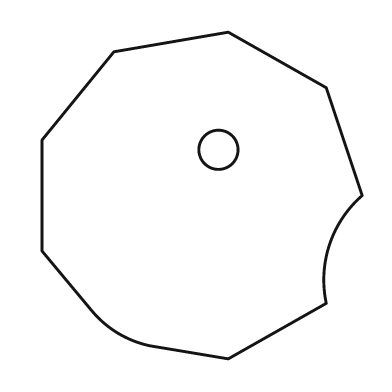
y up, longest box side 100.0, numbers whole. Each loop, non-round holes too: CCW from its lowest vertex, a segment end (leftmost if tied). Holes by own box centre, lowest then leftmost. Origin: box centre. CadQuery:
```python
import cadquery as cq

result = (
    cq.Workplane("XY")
    .moveTo(8.0, -50.0)
    .lineTo(38.0, -33.0)
    .threePointArc((39.0, -15.0), (49.0, 0.0))
    .lineTo(38.0, 33.0)
    .lineTo(8.0, 50.0)
    .lineTo(-27.0, 44.0)
    .lineTo(-49.0, 17.0)
    .lineTo(-49.0, -17.0)
    .lineTo(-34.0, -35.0)
    .threePointArc((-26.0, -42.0), (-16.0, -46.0))
    .close()
    .moveTo(5.0, 14.0)
    .circle(6.0)
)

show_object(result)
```